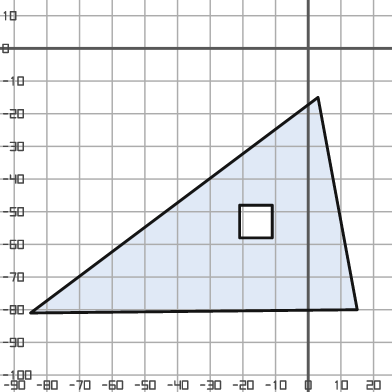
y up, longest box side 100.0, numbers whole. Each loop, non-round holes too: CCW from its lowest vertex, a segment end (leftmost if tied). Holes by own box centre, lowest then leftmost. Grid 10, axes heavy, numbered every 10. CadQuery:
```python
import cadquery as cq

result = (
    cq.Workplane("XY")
    .moveTo(-85.0, -81.0)
    .lineTo(15.0, -80.0)
    .lineTo(3.0, -15.0)
    .close()
    .moveTo(-21.0, -58.0)
    .lineTo(-11.0, -58.0)
    .lineTo(-11.0, -48.0)
    .lineTo(-21.0, -48.0)
    .close()
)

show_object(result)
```